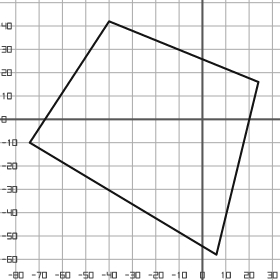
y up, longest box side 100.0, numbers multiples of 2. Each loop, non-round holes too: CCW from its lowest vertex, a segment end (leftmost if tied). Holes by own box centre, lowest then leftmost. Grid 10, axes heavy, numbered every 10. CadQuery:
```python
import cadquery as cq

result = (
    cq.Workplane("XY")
    .moveTo(6.0, -58.0)
    .lineTo(24.0, 16.0)
    .lineTo(-40.0, 42.0)
    .lineTo(-74.0, -10.0)
    .close()
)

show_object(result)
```